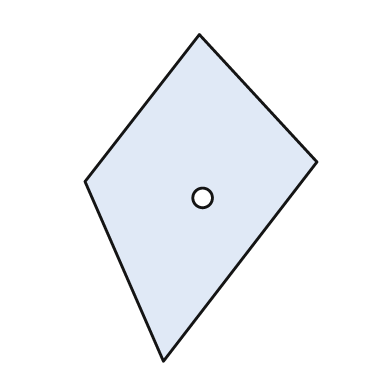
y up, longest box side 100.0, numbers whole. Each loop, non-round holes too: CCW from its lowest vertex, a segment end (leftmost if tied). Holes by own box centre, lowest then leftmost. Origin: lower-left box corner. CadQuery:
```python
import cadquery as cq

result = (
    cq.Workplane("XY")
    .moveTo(24.0, 0.0)
    .lineTo(71.0, 61.0)
    .lineTo(35.0, 100.0)
    .lineTo(0.0, 55.0)
    .close()
    .moveTo(36.0, 50.0)
    .circle(3.0)
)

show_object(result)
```